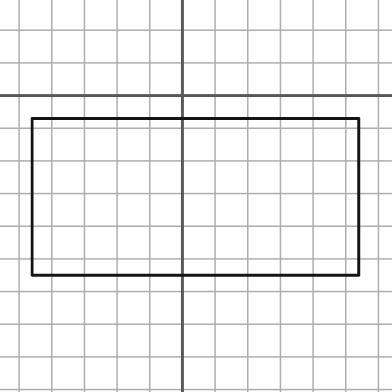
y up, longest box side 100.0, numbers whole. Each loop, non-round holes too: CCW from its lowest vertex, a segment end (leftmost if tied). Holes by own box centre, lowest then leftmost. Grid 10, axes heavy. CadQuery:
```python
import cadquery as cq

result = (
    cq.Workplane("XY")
    .moveTo(-46.0, -55.0)
    .lineTo(54.0, -55.0)
    .lineTo(54.0, -7.0)
    .lineTo(-46.0, -7.0)
    .close()
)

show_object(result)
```